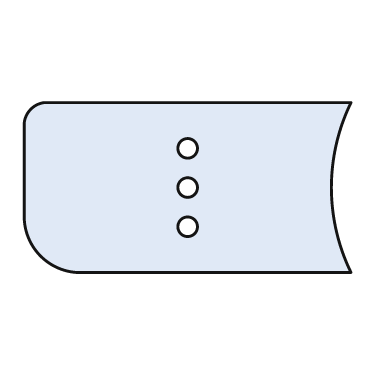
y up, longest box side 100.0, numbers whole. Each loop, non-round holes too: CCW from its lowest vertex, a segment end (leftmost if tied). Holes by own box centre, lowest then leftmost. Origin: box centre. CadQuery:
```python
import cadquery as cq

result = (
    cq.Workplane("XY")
    .moveTo(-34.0, -26.0)
    .lineTo(50.0, -26.0)
    .threePointArc((44.0, 0.0), (50.0, 26.0))
    .lineTo(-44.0, 26.0)
    .threePointArc((-48.0, 24.0), (-50.0, 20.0))
    .lineTo(-50.0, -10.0)
    .threePointArc((-45.0, -21.0), (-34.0, -26.0))
    .close()
    .moveTo(0.0, -12.0)
    .circle(3.0)
    .moveTo(0.0, 0.0)
    .circle(3.0)
    .moveTo(0.0, 12.0)
    .circle(3.0)
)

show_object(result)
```